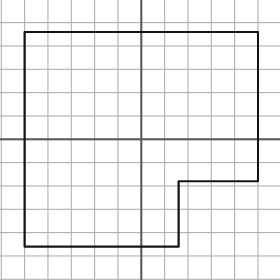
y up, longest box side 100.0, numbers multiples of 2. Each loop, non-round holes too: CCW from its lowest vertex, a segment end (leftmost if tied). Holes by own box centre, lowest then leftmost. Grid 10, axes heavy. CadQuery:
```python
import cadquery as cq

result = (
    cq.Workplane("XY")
    .moveTo(-50.0, -46.0)
    .lineTo(16.0, -46.0)
    .lineTo(16.0, -18.0)
    .lineTo(50.0, -18.0)
    .lineTo(50.0, 46.0)
    .lineTo(-50.0, 46.0)
    .close()
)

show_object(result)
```